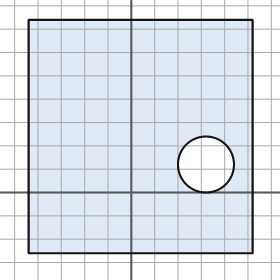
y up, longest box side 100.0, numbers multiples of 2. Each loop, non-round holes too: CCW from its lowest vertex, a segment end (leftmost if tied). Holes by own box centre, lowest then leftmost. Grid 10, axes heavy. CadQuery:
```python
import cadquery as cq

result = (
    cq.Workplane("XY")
    .moveTo(-44.0, -26.0)
    .lineTo(52.0, -26.0)
    .lineTo(52.0, 74.0)
    .lineTo(-44.0, 74.0)
    .close()
    .moveTo(32.0, 12.0)
    .circle(12.0)
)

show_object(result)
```